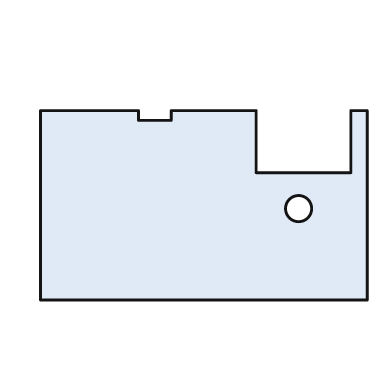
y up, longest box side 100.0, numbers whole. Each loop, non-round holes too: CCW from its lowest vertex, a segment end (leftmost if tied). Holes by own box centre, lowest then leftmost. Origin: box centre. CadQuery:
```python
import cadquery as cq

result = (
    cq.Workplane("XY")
    .moveTo(-50.0, -29.0)
    .lineTo(50.0, -29.0)
    .lineTo(50.0, 29.0)
    .lineTo(45.0, 29.0)
    .lineTo(45.0, 10.0)
    .lineTo(16.0, 10.0)
    .lineTo(16.0, 29.0)
    .lineTo(-10.0, 29.0)
    .lineTo(-10.0, 26.0)
    .lineTo(-20.0, 26.0)
    .lineTo(-20.0, 29.0)
    .lineTo(-50.0, 29.0)
    .close()
    .moveTo(29.0, -1.0)
    .circle(4.0)
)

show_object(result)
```